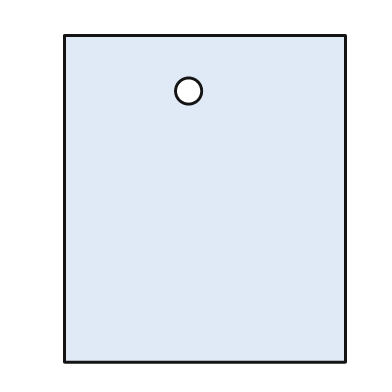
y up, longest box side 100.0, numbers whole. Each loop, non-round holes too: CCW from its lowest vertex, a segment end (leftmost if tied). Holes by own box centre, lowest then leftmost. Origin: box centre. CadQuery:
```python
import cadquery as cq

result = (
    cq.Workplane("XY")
    .moveTo(-43.0, -50.0)
    .lineTo(43.0, -50.0)
    .lineTo(43.0, 50.0)
    .lineTo(-43.0, 50.0)
    .close()
    .moveTo(-5.0, 33.0)
    .circle(4.0)
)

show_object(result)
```